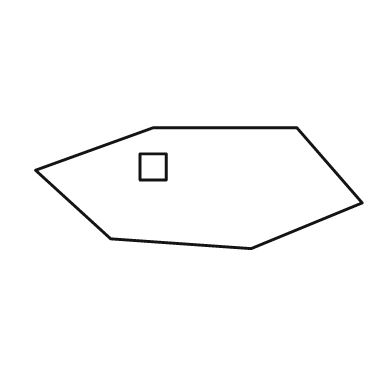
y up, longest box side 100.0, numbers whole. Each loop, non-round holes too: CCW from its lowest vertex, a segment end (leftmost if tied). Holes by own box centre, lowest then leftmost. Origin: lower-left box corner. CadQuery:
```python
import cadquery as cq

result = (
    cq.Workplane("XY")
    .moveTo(66.0, 0.0)
    .lineTo(100.0, 14.0)
    .lineTo(80.0, 37.0)
    .lineTo(36.0, 37.0)
    .lineTo(0.0, 24.0)
    .lineTo(23.0, 3.0)
    .close()
    .moveTo(32.0, 21.0)
    .lineTo(40.0, 21.0)
    .lineTo(40.0, 29.0)
    .lineTo(32.0, 29.0)
    .close()
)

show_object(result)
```